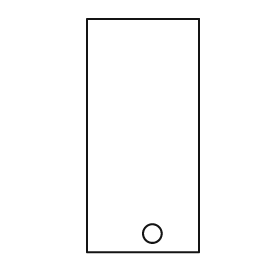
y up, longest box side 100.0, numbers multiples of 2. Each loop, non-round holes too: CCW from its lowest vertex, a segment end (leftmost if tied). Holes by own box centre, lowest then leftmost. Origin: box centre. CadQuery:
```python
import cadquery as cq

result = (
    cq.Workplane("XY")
    .moveTo(-24.0, -50.0)
    .lineTo(24.0, -50.0)
    .lineTo(24.0, 50.0)
    .lineTo(-24.0, 50.0)
    .close()
    .moveTo(4.0, -42.0)
    .circle(4.0)
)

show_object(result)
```